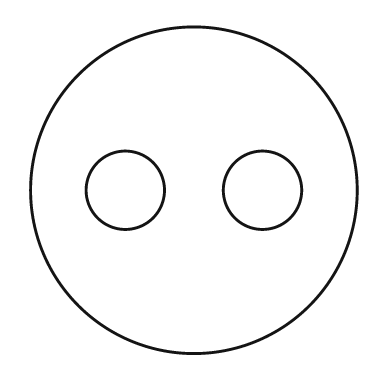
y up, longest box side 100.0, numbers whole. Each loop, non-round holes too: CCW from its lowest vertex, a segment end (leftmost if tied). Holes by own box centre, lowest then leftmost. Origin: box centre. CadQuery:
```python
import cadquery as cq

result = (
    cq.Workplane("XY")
    .moveTo(0.0, 0.0)
    .circle(50.0)
    .moveTo(-21.0, 0.0)
    .circle(12.0)
    .moveTo(21.0, 0.0)
    .circle(12.0)
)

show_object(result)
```